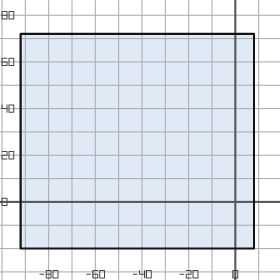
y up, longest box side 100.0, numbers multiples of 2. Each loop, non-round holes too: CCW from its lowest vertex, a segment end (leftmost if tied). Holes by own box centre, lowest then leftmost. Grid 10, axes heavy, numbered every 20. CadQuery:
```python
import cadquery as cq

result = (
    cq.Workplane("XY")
    .moveTo(-92.0, -20.0)
    .lineTo(8.0, -20.0)
    .lineTo(8.0, 72.0)
    .lineTo(-92.0, 72.0)
    .close()
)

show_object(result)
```